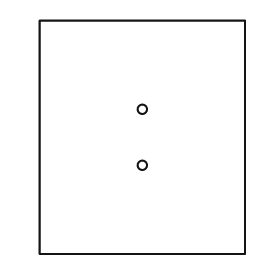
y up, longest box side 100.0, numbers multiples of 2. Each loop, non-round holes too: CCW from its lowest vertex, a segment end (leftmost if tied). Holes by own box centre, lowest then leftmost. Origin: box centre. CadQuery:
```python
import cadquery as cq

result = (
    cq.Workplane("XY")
    .moveTo(-44.0, -50.0)
    .lineTo(44.0, -50.0)
    .lineTo(44.0, 50.0)
    .lineTo(-44.0, 50.0)
    .close()
    .moveTo(0.0, -12.0)
    .circle(2.0)
    .moveTo(0.0, 12.0)
    .circle(2.0)
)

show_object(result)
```